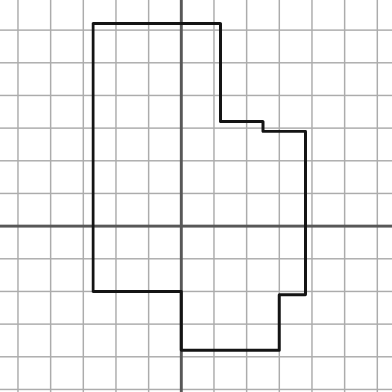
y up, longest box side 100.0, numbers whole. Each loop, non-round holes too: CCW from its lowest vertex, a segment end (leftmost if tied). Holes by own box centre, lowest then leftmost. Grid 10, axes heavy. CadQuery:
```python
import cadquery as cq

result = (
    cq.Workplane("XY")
    .moveTo(0.0, -38.0)
    .lineTo(30.0, -38.0)
    .lineTo(30.0, -21.0)
    .lineTo(38.0, -21.0)
    .lineTo(38.0, 29.0)
    .lineTo(25.0, 29.0)
    .lineTo(25.0, 32.0)
    .lineTo(12.0, 32.0)
    .lineTo(12.0, 62.0)
    .lineTo(-27.0, 62.0)
    .lineTo(-27.0, -20.0)
    .lineTo(0.0, -20.0)
    .close()
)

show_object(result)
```